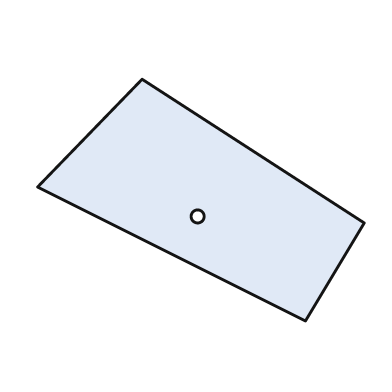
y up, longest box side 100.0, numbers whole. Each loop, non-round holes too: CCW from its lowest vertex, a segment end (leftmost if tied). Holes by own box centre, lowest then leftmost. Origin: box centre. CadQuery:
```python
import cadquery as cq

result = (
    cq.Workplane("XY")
    .moveTo(32.0, -37.0)
    .lineTo(50.0, -7.0)
    .lineTo(-18.0, 37.0)
    .lineTo(-50.0, 4.0)
    .close()
    .moveTo(-1.0, -5.0)
    .circle(2.0)
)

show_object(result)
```